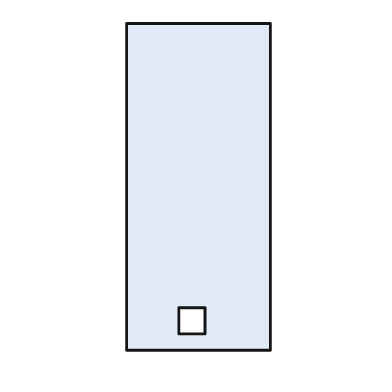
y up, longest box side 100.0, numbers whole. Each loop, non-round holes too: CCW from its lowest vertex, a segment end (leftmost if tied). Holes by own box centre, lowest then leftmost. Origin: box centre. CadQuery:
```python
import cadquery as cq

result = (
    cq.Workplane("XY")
    .moveTo(-22.0, -50.0)
    .lineTo(22.0, -50.0)
    .lineTo(22.0, 50.0)
    .lineTo(-22.0, 50.0)
    .close()
    .moveTo(-6.0, -45.0)
    .lineTo(2.0, -45.0)
    .lineTo(2.0, -37.0)
    .lineTo(-6.0, -37.0)
    .close()
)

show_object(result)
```